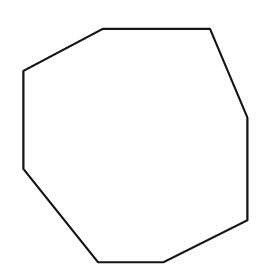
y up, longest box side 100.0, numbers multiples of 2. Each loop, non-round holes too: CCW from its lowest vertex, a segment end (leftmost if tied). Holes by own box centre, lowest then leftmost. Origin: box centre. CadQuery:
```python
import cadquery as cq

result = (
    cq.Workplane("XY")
    .moveTo(-16.0, -50.0)
    .lineTo(12.0, -50.0)
    .lineTo(48.0, -32.0)
    .lineTo(48.0, 12.0)
    .lineTo(32.0, 50.0)
    .lineTo(-14.0, 50.0)
    .lineTo(-48.0, 32.0)
    .lineTo(-48.0, -10.0)
    .close()
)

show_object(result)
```